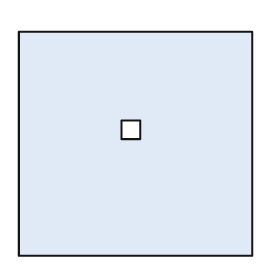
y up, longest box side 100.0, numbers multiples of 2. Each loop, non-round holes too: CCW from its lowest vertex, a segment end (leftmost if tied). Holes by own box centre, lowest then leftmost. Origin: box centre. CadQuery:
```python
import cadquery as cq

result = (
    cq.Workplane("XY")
    .moveTo(-50.0, -48.0)
    .lineTo(50.0, -48.0)
    .lineTo(50.0, 48.0)
    .lineTo(-50.0, 48.0)
    .close()
    .moveTo(-6.0, 2.0)
    .lineTo(2.0, 2.0)
    .lineTo(2.0, 10.0)
    .lineTo(-6.0, 10.0)
    .close()
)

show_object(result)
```